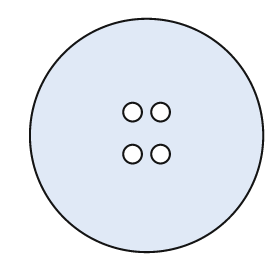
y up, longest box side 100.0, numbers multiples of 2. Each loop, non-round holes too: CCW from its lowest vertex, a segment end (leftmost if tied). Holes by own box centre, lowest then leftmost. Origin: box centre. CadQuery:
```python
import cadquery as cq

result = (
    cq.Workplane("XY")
    .moveTo(0.0, 0.0)
    .circle(50.0)
    .moveTo(-6.0, -8.0)
    .circle(4.0)
    .moveTo(6.0, -8.0)
    .circle(4.0)
    .moveTo(-6.0, 10.0)
    .circle(4.0)
    .moveTo(6.0, 10.0)
    .circle(4.0)
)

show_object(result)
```